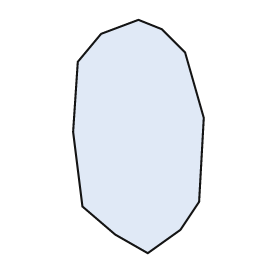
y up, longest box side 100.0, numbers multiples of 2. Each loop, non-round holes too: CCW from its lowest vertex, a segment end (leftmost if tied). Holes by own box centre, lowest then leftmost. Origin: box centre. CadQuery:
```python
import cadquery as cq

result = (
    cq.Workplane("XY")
    .moveTo(4.0, -50.0)
    .lineTo(18.0, -40.0)
    .lineTo(26.0, -28.0)
    .lineTo(28.0, 8.0)
    .lineTo(20.0, 36.0)
    .lineTo(10.0, 46.0)
    .lineTo(0.0, 50.0)
    .lineTo(-16.0, 44.0)
    .lineTo(-26.0, 32.0)
    .lineTo(-28.0, 2.0)
    .lineTo(-24.0, -30.0)
    .lineTo(-10.0, -42.0)
    .close()
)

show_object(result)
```